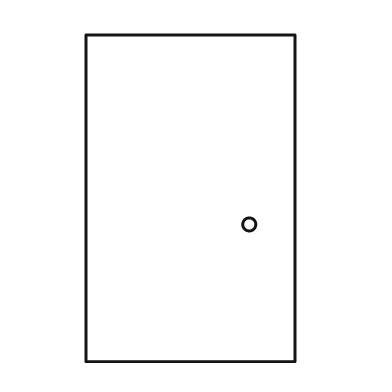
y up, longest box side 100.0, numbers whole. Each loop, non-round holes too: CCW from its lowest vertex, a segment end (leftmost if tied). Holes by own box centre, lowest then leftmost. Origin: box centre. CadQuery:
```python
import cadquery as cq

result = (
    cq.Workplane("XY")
    .moveTo(-32.0, -50.0)
    .lineTo(32.0, -50.0)
    .lineTo(32.0, 50.0)
    .lineTo(-32.0, 50.0)
    .close()
    .moveTo(18.0, -8.0)
    .circle(2.0)
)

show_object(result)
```